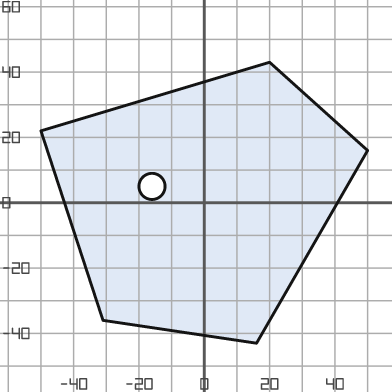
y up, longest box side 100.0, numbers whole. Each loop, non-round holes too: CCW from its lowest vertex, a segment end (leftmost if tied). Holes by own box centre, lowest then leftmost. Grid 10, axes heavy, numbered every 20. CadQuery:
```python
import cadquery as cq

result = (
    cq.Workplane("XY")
    .moveTo(16.0, -43.0)
    .lineTo(50.0, 16.0)
    .lineTo(20.0, 43.0)
    .lineTo(-50.0, 22.0)
    .lineTo(-31.0, -36.0)
    .close()
    .moveTo(-16.0, 5.0)
    .circle(4.0)
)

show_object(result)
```